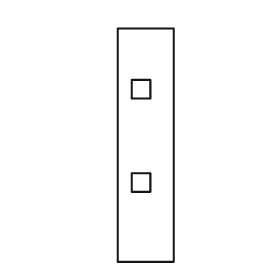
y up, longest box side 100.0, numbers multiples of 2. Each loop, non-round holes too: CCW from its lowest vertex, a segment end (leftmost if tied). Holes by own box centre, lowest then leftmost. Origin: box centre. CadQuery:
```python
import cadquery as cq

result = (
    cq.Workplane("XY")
    .moveTo(-12.0, -50.0)
    .lineTo(12.0, -50.0)
    .lineTo(12.0, 50.0)
    .lineTo(-12.0, 50.0)
    .close()
    .moveTo(-6.0, -20.0)
    .lineTo(2.0, -20.0)
    .lineTo(2.0, -12.0)
    .lineTo(-6.0, -12.0)
    .close()
    .moveTo(-6.0, 20.0)
    .lineTo(2.0, 20.0)
    .lineTo(2.0, 28.0)
    .lineTo(-6.0, 28.0)
    .close()
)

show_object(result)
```